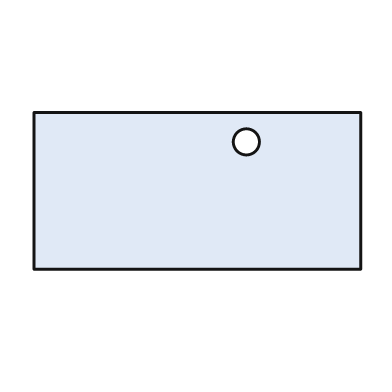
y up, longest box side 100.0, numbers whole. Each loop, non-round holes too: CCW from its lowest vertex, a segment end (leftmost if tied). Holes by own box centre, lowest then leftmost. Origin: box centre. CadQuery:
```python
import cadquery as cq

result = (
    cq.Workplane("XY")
    .moveTo(-50.0, -24.0)
    .lineTo(50.0, -24.0)
    .lineTo(50.0, 24.0)
    .lineTo(-50.0, 24.0)
    .close()
    .moveTo(15.0, 15.0)
    .circle(4.0)
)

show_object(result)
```